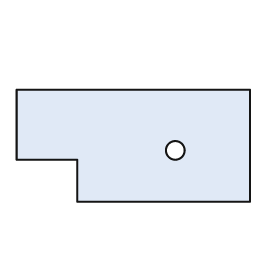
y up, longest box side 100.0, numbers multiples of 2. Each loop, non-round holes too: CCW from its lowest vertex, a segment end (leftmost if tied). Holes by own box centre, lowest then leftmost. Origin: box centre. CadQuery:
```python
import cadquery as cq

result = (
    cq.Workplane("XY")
    .moveTo(-24.0, -24.0)
    .lineTo(50.0, -24.0)
    .lineTo(50.0, 24.0)
    .lineTo(-50.0, 24.0)
    .lineTo(-50.0, -6.0)
    .lineTo(-24.0, -6.0)
    .close()
    .moveTo(18.0, -2.0)
    .circle(4.0)
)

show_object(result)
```